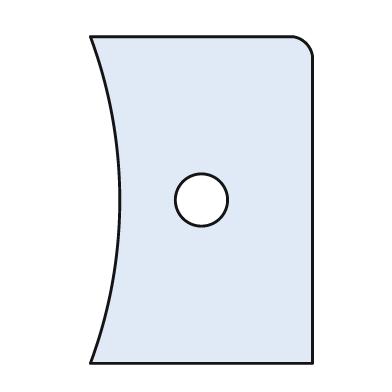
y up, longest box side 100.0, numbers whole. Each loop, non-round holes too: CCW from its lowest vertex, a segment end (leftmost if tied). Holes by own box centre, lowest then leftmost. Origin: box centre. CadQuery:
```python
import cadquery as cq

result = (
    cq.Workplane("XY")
    .moveTo(-34.0, -50.0)
    .lineTo(34.0, -50.0)
    .lineTo(34.0, 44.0)
    .threePointArc((32.0, 48.0), (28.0, 50.0))
    .lineTo(-34.0, 50.0)
    .threePointArc((-25.0, 0.0), (-34.0, -50.0))
    .close()
    .moveTo(0.0, 0.0)
    .circle(8.0)
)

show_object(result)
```